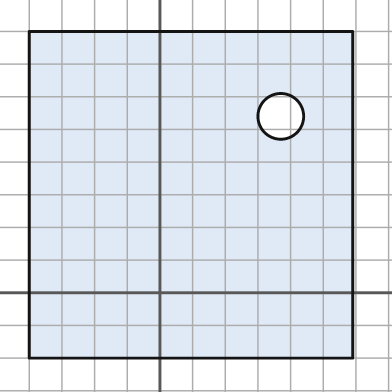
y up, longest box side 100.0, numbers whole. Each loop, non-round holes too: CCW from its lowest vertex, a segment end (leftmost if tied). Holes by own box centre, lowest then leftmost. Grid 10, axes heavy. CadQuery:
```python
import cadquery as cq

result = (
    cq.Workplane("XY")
    .moveTo(-40.0, -20.0)
    .lineTo(59.0, -20.0)
    .lineTo(59.0, 80.0)
    .lineTo(-40.0, 80.0)
    .close()
    .moveTo(37.0, 54.0)
    .circle(7.0)
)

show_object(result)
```